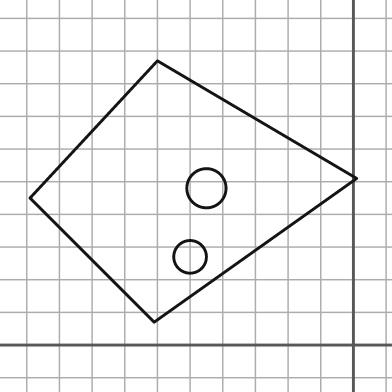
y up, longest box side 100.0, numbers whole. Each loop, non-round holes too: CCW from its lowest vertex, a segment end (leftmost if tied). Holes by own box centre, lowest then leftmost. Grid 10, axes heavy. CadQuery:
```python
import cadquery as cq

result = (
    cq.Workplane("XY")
    .moveTo(-61.0, 7.0)
    .lineTo(1.0, 51.0)
    .lineTo(-60.0, 87.0)
    .lineTo(-99.0, 45.0)
    .close()
    .moveTo(-50.0, 27.0)
    .circle(5.0)
    .moveTo(-45.0, 48.0)
    .circle(6.0)
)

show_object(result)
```